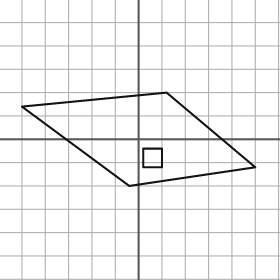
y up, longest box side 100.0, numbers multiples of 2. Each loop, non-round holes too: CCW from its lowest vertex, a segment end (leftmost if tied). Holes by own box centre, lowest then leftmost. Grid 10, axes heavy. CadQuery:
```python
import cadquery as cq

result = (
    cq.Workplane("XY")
    .moveTo(-4.0, -20.0)
    .lineTo(50.0, -12.0)
    .lineTo(12.0, 20.0)
    .lineTo(-50.0, 14.0)
    .close()
    .moveTo(2.0, -12.0)
    .lineTo(10.0, -12.0)
    .lineTo(10.0, -4.0)
    .lineTo(2.0, -4.0)
    .close()
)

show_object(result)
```